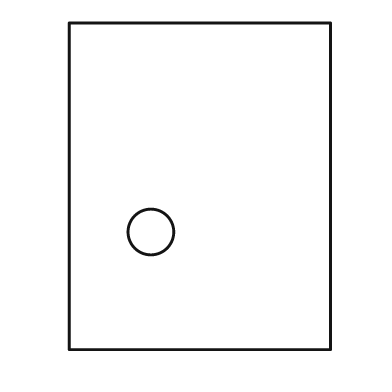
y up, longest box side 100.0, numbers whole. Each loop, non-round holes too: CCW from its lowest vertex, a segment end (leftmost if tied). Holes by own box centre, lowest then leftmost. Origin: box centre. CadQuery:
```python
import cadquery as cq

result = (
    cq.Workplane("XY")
    .moveTo(-40.0, -50.0)
    .lineTo(40.0, -50.0)
    .lineTo(40.0, 50.0)
    .lineTo(-40.0, 50.0)
    .close()
    .moveTo(-15.0, -14.0)
    .circle(7.0)
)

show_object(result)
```